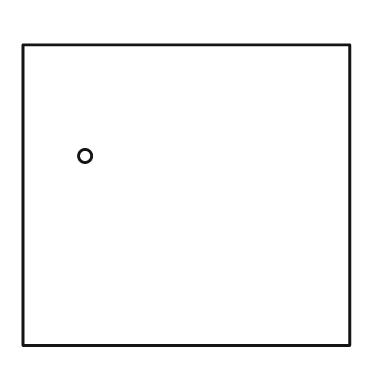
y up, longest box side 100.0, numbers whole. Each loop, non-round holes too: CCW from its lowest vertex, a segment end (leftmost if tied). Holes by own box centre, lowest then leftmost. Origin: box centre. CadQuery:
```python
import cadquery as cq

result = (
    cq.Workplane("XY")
    .moveTo(-50.0, -46.0)
    .lineTo(50.0, -46.0)
    .lineTo(50.0, 46.0)
    .lineTo(-50.0, 46.0)
    .close()
    .moveTo(-31.0, 12.0)
    .circle(2.0)
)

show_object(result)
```